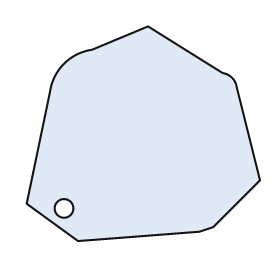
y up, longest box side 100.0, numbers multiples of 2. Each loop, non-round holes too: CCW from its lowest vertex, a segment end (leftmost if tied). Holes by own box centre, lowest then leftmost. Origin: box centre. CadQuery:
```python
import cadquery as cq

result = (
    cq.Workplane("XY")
    .moveTo(-28.0, -46.0)
    .lineTo(24.0, -42.0)
    .lineTo(30.0, -40.0)
    .lineTo(50.0, -20.0)
    .lineTo(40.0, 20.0)
    .threePointArc((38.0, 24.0), (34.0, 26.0))
    .lineTo(2.0, 46.0)
    .lineTo(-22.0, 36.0)
    .threePointArc((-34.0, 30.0), (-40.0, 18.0))
    .lineTo(-50.0, -30.0)
    .close()
    .moveTo(-34.0, -32.0)
    .circle(4.0)
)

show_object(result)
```